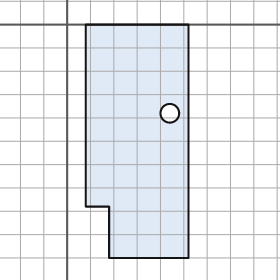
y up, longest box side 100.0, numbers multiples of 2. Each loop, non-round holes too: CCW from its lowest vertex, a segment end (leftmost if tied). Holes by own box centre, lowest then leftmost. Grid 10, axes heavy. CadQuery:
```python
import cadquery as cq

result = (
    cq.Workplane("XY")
    .moveTo(18.0, -100.0)
    .lineTo(52.0, -100.0)
    .lineTo(52.0, 0.0)
    .lineTo(8.0, 0.0)
    .lineTo(8.0, -78.0)
    .lineTo(18.0, -78.0)
    .close()
    .moveTo(44.0, -38.0)
    .circle(4.0)
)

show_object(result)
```